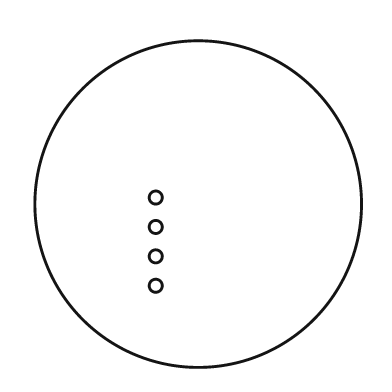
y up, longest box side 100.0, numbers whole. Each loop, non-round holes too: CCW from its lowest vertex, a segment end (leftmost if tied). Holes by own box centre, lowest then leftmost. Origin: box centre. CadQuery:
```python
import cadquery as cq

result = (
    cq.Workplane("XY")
    .moveTo(0.0, 0.0)
    .circle(50.0)
    .moveTo(-13.0, -25.0)
    .circle(2.0)
    .moveTo(-13.0, -16.0)
    .circle(2.0)
    .moveTo(-13.0, -7.0)
    .circle(2.0)
    .moveTo(-13.0, 2.0)
    .circle(2.0)
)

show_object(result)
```